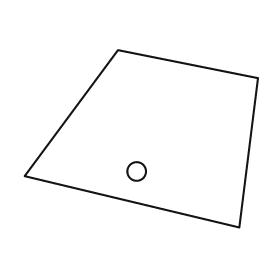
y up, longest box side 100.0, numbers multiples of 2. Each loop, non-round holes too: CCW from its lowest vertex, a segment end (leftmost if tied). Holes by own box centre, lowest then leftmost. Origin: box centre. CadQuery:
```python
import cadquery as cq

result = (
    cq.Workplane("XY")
    .moveTo(42.0, -38.0)
    .lineTo(50.0, 26.0)
    .lineTo(-10.0, 38.0)
    .lineTo(-50.0, -16.0)
    .close()
    .moveTo(-2.0, -14.0)
    .circle(4.0)
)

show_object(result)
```